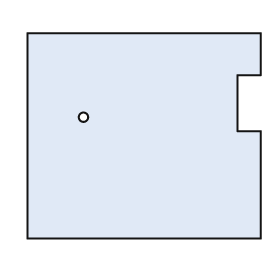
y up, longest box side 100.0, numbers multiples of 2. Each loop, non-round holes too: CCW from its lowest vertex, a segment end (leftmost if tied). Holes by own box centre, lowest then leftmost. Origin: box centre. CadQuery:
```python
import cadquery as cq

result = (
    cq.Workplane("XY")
    .moveTo(-50.0, -44.0)
    .lineTo(50.0, -44.0)
    .lineTo(50.0, 2.0)
    .lineTo(40.0, 2.0)
    .lineTo(40.0, 26.0)
    .lineTo(50.0, 26.0)
    .lineTo(50.0, 44.0)
    .lineTo(-50.0, 44.0)
    .close()
    .moveTo(-26.0, 8.0)
    .circle(2.0)
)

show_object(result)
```